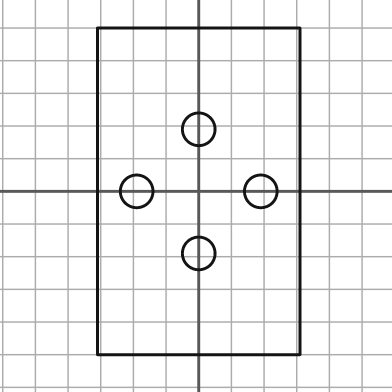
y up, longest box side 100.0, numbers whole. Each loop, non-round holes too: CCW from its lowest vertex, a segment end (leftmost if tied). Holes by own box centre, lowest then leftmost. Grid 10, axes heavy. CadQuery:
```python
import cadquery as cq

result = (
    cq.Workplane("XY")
    .moveTo(-31.0, -50.0)
    .lineTo(31.0, -50.0)
    .lineTo(31.0, 50.0)
    .lineTo(-31.0, 50.0)
    .close()
    .moveTo(0.0, -19.0)
    .circle(5.0)
    .moveTo(-19.0, 0.0)
    .circle(5.0)
    .moveTo(19.0, 0.0)
    .circle(5.0)
    .moveTo(0.0, 19.0)
    .circle(5.0)
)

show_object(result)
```